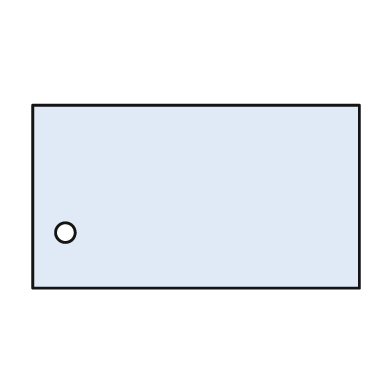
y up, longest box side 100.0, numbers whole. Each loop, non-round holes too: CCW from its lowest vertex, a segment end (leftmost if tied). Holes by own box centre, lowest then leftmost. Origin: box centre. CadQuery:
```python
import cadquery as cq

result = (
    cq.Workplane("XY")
    .moveTo(-50.0, -28.0)
    .lineTo(50.0, -28.0)
    .lineTo(50.0, 28.0)
    .lineTo(-50.0, 28.0)
    .close()
    .moveTo(-40.0, -11.0)
    .circle(3.0)
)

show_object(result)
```